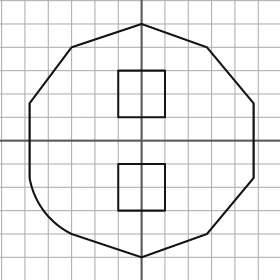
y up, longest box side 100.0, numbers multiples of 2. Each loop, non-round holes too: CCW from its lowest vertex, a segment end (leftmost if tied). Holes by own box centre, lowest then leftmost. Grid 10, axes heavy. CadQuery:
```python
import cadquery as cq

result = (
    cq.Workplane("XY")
    .moveTo(0.0, -50.0)
    .lineTo(28.0, -40.0)
    .lineTo(48.0, -16.0)
    .lineTo(48.0, 16.0)
    .lineTo(28.0, 40.0)
    .lineTo(0.0, 50.0)
    .lineTo(-30.0, 40.0)
    .lineTo(-48.0, 16.0)
    .lineTo(-48.0, -16.0)
    .threePointArc((-42.0, -30.0), (-30.0, -40.0))
    .close()
    .moveTo(-10.0, -30.0)
    .lineTo(10.0, -30.0)
    .lineTo(10.0, -10.0)
    .lineTo(-10.0, -10.0)
    .close()
    .moveTo(-10.0, 10.0)
    .lineTo(10.0, 10.0)
    .lineTo(10.0, 30.0)
    .lineTo(-10.0, 30.0)
    .close()
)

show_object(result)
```